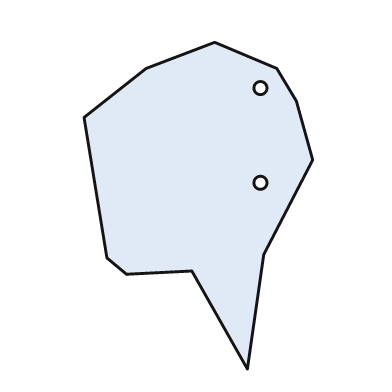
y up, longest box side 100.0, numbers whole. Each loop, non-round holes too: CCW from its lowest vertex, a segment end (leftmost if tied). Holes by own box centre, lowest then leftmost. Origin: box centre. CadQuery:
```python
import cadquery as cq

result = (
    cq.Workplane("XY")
    .moveTo(15.0, -50.0)
    .lineTo(20.0, -15.0)
    .lineTo(35.0, 14.0)
    .lineTo(30.0, 32.0)
    .lineTo(24.0, 42.0)
    .lineTo(5.0, 50.0)
    .lineTo(-16.0, 42.0)
    .lineTo(-35.0, 27.0)
    .lineTo(-28.0, -16.0)
    .lineTo(-22.0, -21.0)
    .lineTo(-2.0, -20.0)
    .close()
    .moveTo(19.0, 7.0)
    .circle(2.0)
    .moveTo(19.0, 36.0)
    .circle(2.0)
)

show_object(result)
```